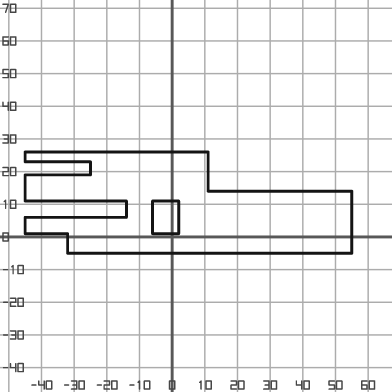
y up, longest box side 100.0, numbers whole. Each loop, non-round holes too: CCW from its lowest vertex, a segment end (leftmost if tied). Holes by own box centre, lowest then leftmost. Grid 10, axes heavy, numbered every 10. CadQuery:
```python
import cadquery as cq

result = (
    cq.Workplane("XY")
    .moveTo(-32.0, -5.0)
    .lineTo(55.0, -5.0)
    .lineTo(55.0, 14.0)
    .lineTo(11.0, 14.0)
    .lineTo(11.0, 26.0)
    .lineTo(-45.0, 26.0)
    .lineTo(-45.0, 23.0)
    .lineTo(-25.0, 23.0)
    .lineTo(-25.0, 19.0)
    .lineTo(-45.0, 19.0)
    .lineTo(-45.0, 11.0)
    .lineTo(-14.0, 11.0)
    .lineTo(-14.0, 6.0)
    .lineTo(-45.0, 6.0)
    .lineTo(-45.0, 1.0)
    .lineTo(-32.0, 1.0)
    .close()
    .moveTo(-6.0, 1.0)
    .lineTo(2.0, 1.0)
    .lineTo(2.0, 11.0)
    .lineTo(-6.0, 11.0)
    .close()
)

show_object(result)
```